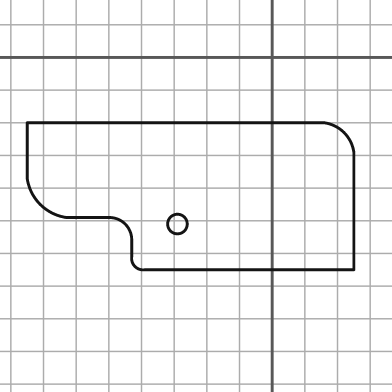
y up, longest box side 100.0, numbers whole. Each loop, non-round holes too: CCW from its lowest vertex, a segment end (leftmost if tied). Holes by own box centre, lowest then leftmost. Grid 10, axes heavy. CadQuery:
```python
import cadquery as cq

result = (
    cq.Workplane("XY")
    .moveTo(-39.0, -65.0)
    .lineTo(25.0, -65.0)
    .lineTo(25.0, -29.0)
    .threePointArc((22.0, -23.0), (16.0, -20.0))
    .lineTo(-75.0, -20.0)
    .lineTo(-75.0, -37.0)
    .threePointArc((-71.0, -45.0), (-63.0, -49.0))
    .lineTo(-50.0, -49.0)
    .threePointArc((-45.0, -51.0), (-43.0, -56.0))
    .lineTo(-43.0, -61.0)
    .threePointArc((-42.0, -64.0), (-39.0, -65.0))
    .close()
    .moveTo(-29.0, -51.0)
    .circle(3.0)
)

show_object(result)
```